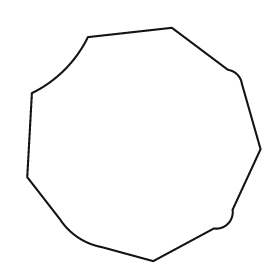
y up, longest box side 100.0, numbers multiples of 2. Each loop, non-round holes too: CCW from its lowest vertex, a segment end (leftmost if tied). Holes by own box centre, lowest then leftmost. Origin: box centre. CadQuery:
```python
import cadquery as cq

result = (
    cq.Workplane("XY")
    .moveTo(4.0, -50.0)
    .lineTo(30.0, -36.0)
    .threePointArc((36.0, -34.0), (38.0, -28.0))
    .lineTo(50.0, -2.0)
    .lineTo(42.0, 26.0)
    .threePointArc((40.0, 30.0), (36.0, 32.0))
    .lineTo(12.0, 50.0)
    .lineTo(-24.0, 46.0)
    .threePointArc((-34.0, 32.0), (-48.0, 22.0))
    .lineTo(-50.0, -14.0)
    .lineTo(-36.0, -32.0)
    .threePointArc((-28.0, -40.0), (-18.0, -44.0))
    .close()
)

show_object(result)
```